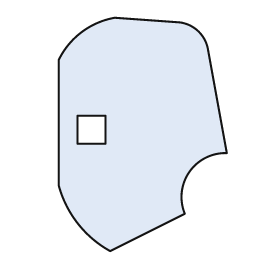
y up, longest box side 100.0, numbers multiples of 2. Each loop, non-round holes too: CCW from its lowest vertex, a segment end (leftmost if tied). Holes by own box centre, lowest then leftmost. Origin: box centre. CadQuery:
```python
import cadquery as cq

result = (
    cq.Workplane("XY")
    .moveTo(-14.0, -50.0)
    .lineTo(18.0, -34.0)
    .threePointArc((20.0, -16.0), (36.0, -8.0))
    .lineTo(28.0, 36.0)
    .threePointArc((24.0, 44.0), (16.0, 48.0))
    .lineTo(-12.0, 50.0)
    .threePointArc((-26.0, 44.0), (-36.0, 32.0))
    .lineTo(-36.0, -22.0)
    .threePointArc((-28.0, -38.0), (-14.0, -50.0))
    .close()
    .moveTo(-28.0, -4.0)
    .lineTo(-16.0, -4.0)
    .lineTo(-16.0, 8.0)
    .lineTo(-28.0, 8.0)
    .close()
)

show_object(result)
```